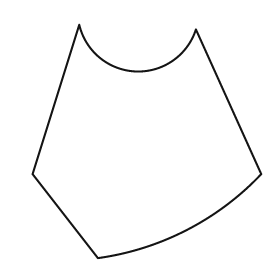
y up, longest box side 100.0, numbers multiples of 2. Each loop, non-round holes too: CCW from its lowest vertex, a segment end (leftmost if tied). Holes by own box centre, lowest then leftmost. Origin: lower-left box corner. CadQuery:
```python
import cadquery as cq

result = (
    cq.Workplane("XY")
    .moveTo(28.0, 0.0)
    .threePointArc((66.0, 12.0), (98.0, 36.0))
    .lineTo(70.0, 98.0)
    .threePointArc((44.0, 80.0), (20.0, 100.0))
    .lineTo(0.0, 36.0)
    .close()
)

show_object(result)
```